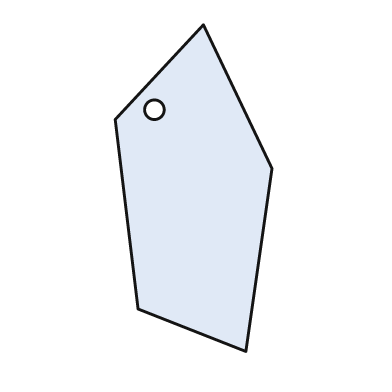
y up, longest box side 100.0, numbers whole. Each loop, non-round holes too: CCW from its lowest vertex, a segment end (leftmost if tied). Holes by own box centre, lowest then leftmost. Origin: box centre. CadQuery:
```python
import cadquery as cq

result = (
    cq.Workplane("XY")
    .moveTo(16.0, -50.0)
    .lineTo(24.0, 6.0)
    .lineTo(3.0, 50.0)
    .lineTo(-24.0, 21.0)
    .lineTo(-17.0, -37.0)
    .close()
    .moveTo(-12.0, 24.0)
    .circle(3.0)
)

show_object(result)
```